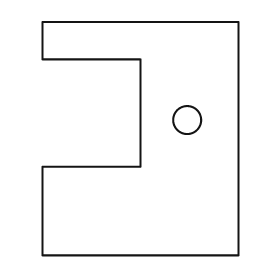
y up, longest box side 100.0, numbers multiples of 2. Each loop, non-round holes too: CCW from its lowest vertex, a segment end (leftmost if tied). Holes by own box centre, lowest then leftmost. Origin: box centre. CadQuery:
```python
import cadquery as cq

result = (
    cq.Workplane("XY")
    .moveTo(-42.0, -50.0)
    .lineTo(42.0, -50.0)
    .lineTo(42.0, 50.0)
    .lineTo(-42.0, 50.0)
    .lineTo(-42.0, 34.0)
    .lineTo(0.0, 34.0)
    .lineTo(0.0, -12.0)
    .lineTo(-42.0, -12.0)
    .close()
    .moveTo(20.0, 8.0)
    .circle(6.0)
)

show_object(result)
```